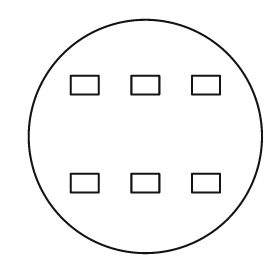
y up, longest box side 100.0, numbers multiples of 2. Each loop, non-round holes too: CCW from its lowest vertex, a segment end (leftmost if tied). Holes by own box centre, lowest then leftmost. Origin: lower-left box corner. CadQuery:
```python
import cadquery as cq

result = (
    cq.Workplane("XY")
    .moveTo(50.0, 50.0)
    .circle(50.0)
    .moveTo(18.0, 26.0)
    .lineTo(30.0, 26.0)
    .lineTo(30.0, 34.0)
    .lineTo(18.0, 34.0)
    .close()
    .moveTo(44.0, 26.0)
    .lineTo(56.0, 26.0)
    .lineTo(56.0, 34.0)
    .lineTo(44.0, 34.0)
    .close()
    .moveTo(70.0, 26.0)
    .lineTo(82.0, 26.0)
    .lineTo(82.0, 34.0)
    .lineTo(70.0, 34.0)
    .close()
    .moveTo(18.0, 68.0)
    .lineTo(30.0, 68.0)
    .lineTo(30.0, 76.0)
    .lineTo(18.0, 76.0)
    .close()
    .moveTo(44.0, 68.0)
    .lineTo(56.0, 68.0)
    .lineTo(56.0, 76.0)
    .lineTo(44.0, 76.0)
    .close()
    .moveTo(70.0, 68.0)
    .lineTo(82.0, 68.0)
    .lineTo(82.0, 76.0)
    .lineTo(70.0, 76.0)
    .close()
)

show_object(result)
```